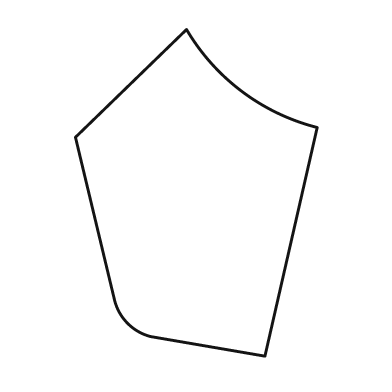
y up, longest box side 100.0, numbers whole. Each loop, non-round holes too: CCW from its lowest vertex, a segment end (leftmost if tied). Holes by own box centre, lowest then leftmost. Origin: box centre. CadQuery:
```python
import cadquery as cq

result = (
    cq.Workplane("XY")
    .moveTo(21.0, -50.0)
    .lineTo(37.0, 20.0)
    .threePointArc((14.0, 31.0), (-3.0, 50.0))
    .lineTo(-37.0, 17.0)
    .lineTo(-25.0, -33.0)
    .threePointArc((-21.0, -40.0), (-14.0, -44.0))
    .close()
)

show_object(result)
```